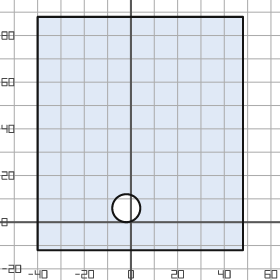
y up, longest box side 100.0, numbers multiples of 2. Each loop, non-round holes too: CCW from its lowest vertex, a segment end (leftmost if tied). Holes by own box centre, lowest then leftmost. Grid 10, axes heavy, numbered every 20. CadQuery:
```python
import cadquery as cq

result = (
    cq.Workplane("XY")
    .moveTo(-40.0, -12.0)
    .lineTo(48.0, -12.0)
    .lineTo(48.0, 88.0)
    .lineTo(-40.0, 88.0)
    .close()
    .moveTo(-2.0, 6.0)
    .circle(6.0)
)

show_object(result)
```